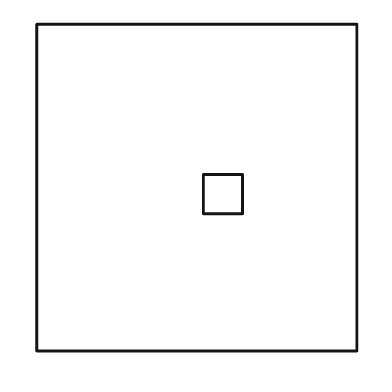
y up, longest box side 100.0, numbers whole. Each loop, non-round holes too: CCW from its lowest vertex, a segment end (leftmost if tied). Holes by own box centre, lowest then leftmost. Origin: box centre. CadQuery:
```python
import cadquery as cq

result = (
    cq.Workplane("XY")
    .moveTo(-49.0, -50.0)
    .lineTo(49.0, -50.0)
    .lineTo(49.0, 50.0)
    .lineTo(-49.0, 50.0)
    .close()
    .moveTo(2.0, -8.0)
    .lineTo(14.0, -8.0)
    .lineTo(14.0, 4.0)
    .lineTo(2.0, 4.0)
    .close()
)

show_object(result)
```